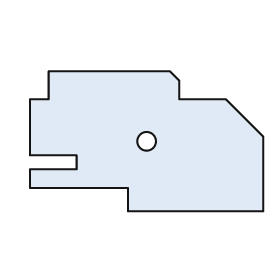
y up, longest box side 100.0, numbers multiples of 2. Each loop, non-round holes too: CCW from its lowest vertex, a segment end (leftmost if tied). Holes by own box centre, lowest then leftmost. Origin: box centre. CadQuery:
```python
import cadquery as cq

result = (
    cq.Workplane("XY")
    .moveTo(-8.0, -30.0)
    .lineTo(50.0, -30.0)
    .lineTo(50.0, 2.0)
    .lineTo(34.0, 18.0)
    .lineTo(14.0, 18.0)
    .lineTo(14.0, 26.0)
    .lineTo(10.0, 30.0)
    .lineTo(-42.0, 30.0)
    .lineTo(-42.0, 18.0)
    .lineTo(-50.0, 18.0)
    .lineTo(-50.0, -6.0)
    .lineTo(-30.0, -6.0)
    .lineTo(-30.0, -12.0)
    .lineTo(-50.0, -12.0)
    .lineTo(-50.0, -20.0)
    .lineTo(-8.0, -20.0)
    .close()
    .moveTo(0.0, 0.0)
    .circle(4.0)
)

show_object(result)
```